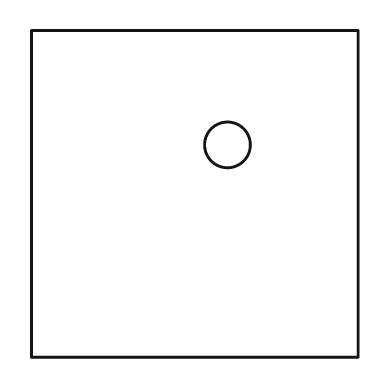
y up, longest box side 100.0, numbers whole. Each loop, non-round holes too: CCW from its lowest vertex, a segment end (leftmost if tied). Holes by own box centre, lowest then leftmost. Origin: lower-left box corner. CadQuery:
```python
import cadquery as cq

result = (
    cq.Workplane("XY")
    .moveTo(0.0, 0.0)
    .lineTo(100.0, 0.0)
    .lineTo(100.0, 100.0)
    .lineTo(0.0, 100.0)
    .close()
    .moveTo(60.0, 65.0)
    .circle(7.0)
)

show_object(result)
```